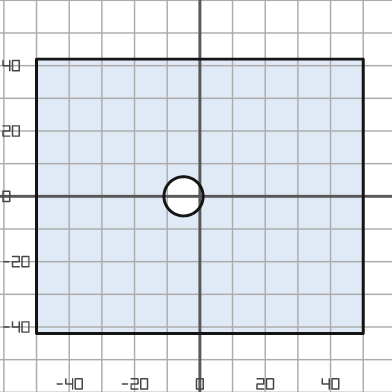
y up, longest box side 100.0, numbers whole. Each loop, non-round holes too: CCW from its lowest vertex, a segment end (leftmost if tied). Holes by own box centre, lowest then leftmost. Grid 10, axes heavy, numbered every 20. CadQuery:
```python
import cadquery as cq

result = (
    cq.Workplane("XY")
    .moveTo(-50.0, -42.0)
    .lineTo(50.0, -42.0)
    .lineTo(50.0, 42.0)
    .lineTo(-50.0, 42.0)
    .close()
    .moveTo(-5.0, 0.0)
    .circle(6.0)
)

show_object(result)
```